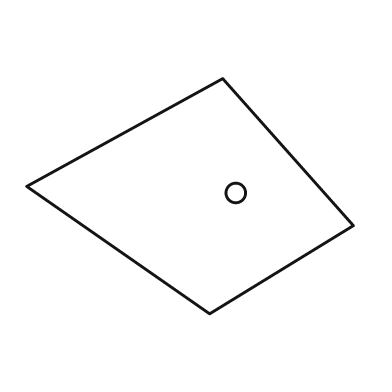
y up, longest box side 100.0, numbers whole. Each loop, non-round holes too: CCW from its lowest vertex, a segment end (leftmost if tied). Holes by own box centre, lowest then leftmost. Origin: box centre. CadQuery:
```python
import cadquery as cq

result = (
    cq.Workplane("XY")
    .moveTo(6.0, -36.0)
    .lineTo(50.0, -9.0)
    .lineTo(10.0, 36.0)
    .lineTo(-50.0, 3.0)
    .close()
    .moveTo(14.0, 1.0)
    .circle(3.0)
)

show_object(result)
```